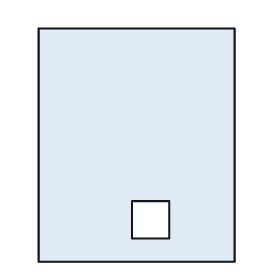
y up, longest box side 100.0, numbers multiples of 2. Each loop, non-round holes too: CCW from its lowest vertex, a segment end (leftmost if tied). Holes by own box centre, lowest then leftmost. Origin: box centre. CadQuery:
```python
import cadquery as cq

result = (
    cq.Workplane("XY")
    .moveTo(-42.0, -50.0)
    .lineTo(42.0, -50.0)
    .lineTo(42.0, 50.0)
    .lineTo(-42.0, 50.0)
    .close()
    .moveTo(-2.0, -40.0)
    .lineTo(14.0, -40.0)
    .lineTo(14.0, -24.0)
    .lineTo(-2.0, -24.0)
    .close()
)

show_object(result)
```